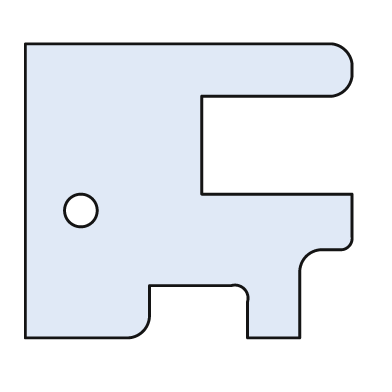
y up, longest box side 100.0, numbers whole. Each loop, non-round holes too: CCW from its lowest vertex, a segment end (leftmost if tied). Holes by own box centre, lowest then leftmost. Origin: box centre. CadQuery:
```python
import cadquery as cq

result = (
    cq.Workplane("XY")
    .moveTo(-50.0, -45.0)
    .lineTo(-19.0, -45.0)
    .threePointArc((-14.0, -43.0), (-12.0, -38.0))
    .lineTo(-12.0, -29.0)
    .lineTo(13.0, -29.0)
    .threePointArc((17.0, -30.0), (18.0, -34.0))
    .lineTo(18.0, -45.0)
    .lineTo(34.0, -45.0)
    .lineTo(34.0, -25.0)
    .threePointArc((36.0, -20.0), (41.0, -18.0))
    .lineTo(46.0, -18.0)
    .threePointArc((49.0, -17.0), (50.0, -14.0))
    .lineTo(50.0, -1.0)
    .lineTo(4.0, -1.0)
    .lineTo(4.0, 29.0)
    .lineTo(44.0, 29.0)
    .threePointArc((48.0, 31.0), (50.0, 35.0))
    .lineTo(50.0, 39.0)
    .threePointArc((48.0, 43.0), (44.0, 45.0))
    .lineTo(-50.0, 45.0)
    .close()
    .moveTo(-33.0, -6.0)
    .circle(5.0)
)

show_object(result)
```